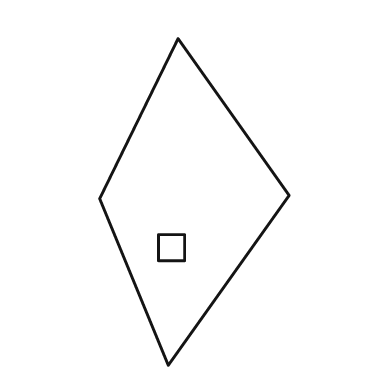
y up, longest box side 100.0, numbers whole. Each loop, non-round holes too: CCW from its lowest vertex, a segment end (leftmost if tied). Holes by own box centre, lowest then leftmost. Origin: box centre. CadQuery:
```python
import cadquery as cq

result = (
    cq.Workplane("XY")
    .moveTo(-8.0, -50.0)
    .lineTo(29.0, 2.0)
    .lineTo(-5.0, 50.0)
    .lineTo(-29.0, 1.0)
    .close()
    .moveTo(-11.0, -18.0)
    .lineTo(-3.0, -18.0)
    .lineTo(-3.0, -10.0)
    .lineTo(-11.0, -10.0)
    .close()
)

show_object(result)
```